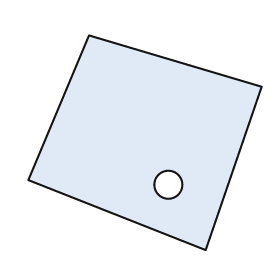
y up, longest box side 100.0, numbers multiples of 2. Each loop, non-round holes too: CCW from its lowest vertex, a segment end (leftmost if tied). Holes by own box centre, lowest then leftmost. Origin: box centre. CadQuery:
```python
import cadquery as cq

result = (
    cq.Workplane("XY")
    .moveTo(26.0, -46.0)
    .lineTo(50.0, 24.0)
    .lineTo(-24.0, 46.0)
    .lineTo(-50.0, -16.0)
    .close()
    .moveTo(10.0, -18.0)
    .circle(6.0)
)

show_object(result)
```